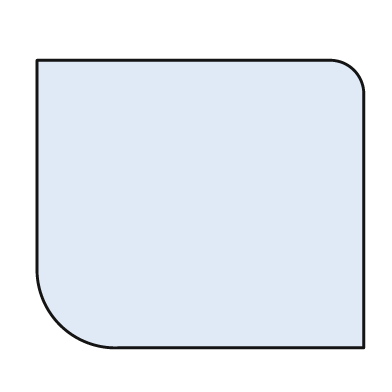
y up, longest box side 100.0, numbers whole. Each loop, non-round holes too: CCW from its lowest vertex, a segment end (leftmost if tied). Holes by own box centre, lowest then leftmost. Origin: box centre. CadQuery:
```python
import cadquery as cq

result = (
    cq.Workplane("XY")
    .moveTo(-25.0, -44.0)
    .lineTo(50.0, -44.0)
    .lineTo(50.0, 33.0)
    .threePointArc((47.0, 41.0), (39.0, 44.0))
    .lineTo(-50.0, 44.0)
    .lineTo(-50.0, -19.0)
    .threePointArc((-43.0, -37.0), (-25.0, -44.0))
    .close()
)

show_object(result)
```